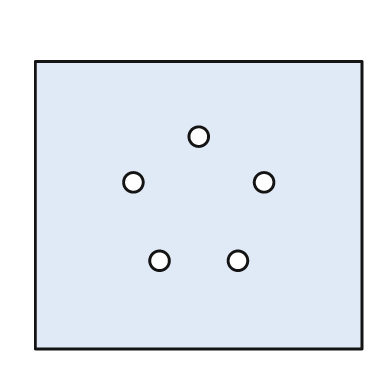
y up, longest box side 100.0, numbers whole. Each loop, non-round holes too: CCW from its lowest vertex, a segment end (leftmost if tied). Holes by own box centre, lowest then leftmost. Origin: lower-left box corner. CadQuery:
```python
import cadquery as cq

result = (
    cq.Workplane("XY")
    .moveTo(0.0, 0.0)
    .lineTo(100.0, 0.0)
    .lineTo(100.0, 88.0)
    .lineTo(0.0, 88.0)
    .close()
    .moveTo(38.0, 27.0)
    .circle(3.0)
    .moveTo(62.0, 27.0)
    .circle(3.0)
    .moveTo(30.0, 51.0)
    .circle(3.0)
    .moveTo(70.0, 51.0)
    .circle(3.0)
    .moveTo(50.0, 65.0)
    .circle(3.0)
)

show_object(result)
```